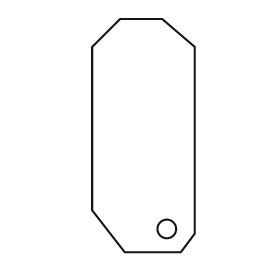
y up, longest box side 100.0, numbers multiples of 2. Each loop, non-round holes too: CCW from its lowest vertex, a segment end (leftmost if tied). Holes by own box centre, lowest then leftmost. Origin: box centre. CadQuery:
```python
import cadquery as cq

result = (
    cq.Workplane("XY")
    .moveTo(-8.0, -50.0)
    .lineTo(16.0, -50.0)
    .lineTo(22.0, -42.0)
    .lineTo(22.0, 38.0)
    .lineTo(8.0, 50.0)
    .lineTo(-10.0, 50.0)
    .lineTo(-22.0, 38.0)
    .lineTo(-22.0, -32.0)
    .close()
    .moveTo(10.0, -40.0)
    .circle(4.0)
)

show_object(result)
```